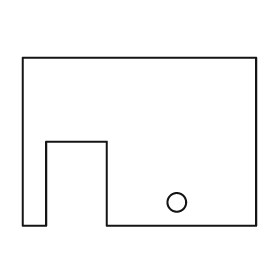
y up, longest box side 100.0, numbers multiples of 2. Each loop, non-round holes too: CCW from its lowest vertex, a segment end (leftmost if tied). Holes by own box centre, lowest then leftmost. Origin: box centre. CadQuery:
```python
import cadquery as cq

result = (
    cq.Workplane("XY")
    .moveTo(-50.0, -36.0)
    .lineTo(-40.0, -36.0)
    .lineTo(-40.0, 0.0)
    .lineTo(-14.0, 0.0)
    .lineTo(-14.0, -36.0)
    .lineTo(50.0, -36.0)
    .lineTo(50.0, 36.0)
    .lineTo(-50.0, 36.0)
    .close()
    .moveTo(16.0, -26.0)
    .circle(4.0)
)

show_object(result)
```